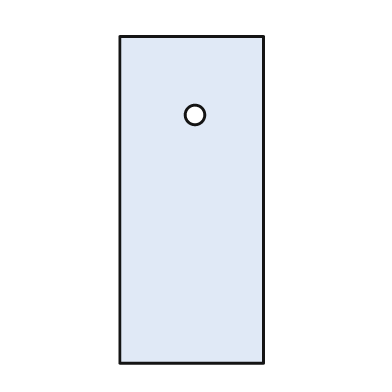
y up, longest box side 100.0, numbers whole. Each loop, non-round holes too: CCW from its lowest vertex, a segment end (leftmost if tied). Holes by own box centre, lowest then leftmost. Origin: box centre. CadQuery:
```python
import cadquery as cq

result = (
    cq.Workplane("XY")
    .moveTo(-22.0, -50.0)
    .lineTo(22.0, -50.0)
    .lineTo(22.0, 50.0)
    .lineTo(-22.0, 50.0)
    .close()
    .moveTo(1.0, 26.0)
    .circle(3.0)
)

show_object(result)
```